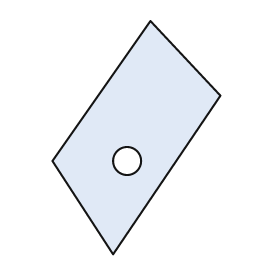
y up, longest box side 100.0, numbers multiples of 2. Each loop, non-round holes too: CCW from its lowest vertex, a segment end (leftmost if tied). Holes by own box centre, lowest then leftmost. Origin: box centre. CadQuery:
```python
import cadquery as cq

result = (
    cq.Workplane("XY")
    .moveTo(-10.0, -50.0)
    .lineTo(36.0, 18.0)
    .lineTo(6.0, 50.0)
    .lineTo(-36.0, -10.0)
    .close()
    .moveTo(-4.0, -10.0)
    .circle(6.0)
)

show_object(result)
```